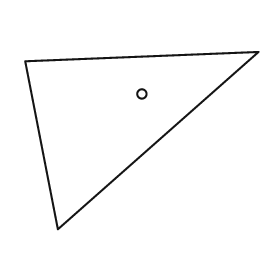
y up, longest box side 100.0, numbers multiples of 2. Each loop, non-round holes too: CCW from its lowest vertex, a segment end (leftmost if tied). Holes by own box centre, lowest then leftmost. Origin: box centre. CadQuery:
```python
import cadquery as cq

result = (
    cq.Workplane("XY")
    .moveTo(-36.0, -38.0)
    .lineTo(50.0, 38.0)
    .lineTo(-50.0, 34.0)
    .close()
    .moveTo(0.0, 20.0)
    .circle(2.0)
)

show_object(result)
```